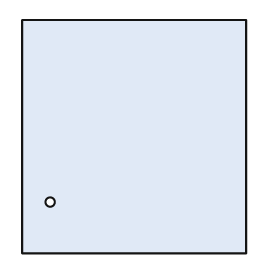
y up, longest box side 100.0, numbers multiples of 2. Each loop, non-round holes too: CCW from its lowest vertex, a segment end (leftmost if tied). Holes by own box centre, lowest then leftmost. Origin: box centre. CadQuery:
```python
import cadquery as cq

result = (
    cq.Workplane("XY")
    .moveTo(-48.0, -50.0)
    .lineTo(48.0, -50.0)
    .lineTo(48.0, 50.0)
    .lineTo(-48.0, 50.0)
    .close()
    .moveTo(-36.0, -28.0)
    .circle(2.0)
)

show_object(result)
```